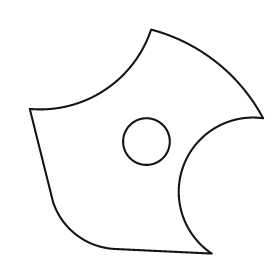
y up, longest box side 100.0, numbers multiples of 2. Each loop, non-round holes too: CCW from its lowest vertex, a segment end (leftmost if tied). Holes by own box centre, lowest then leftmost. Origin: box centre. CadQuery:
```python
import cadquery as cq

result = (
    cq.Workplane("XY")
    .moveTo(28.0, -48.0)
    .threePointArc((16.0, -10.0), (50.0, 10.0))
    .threePointArc((30.0, 34.0), (2.0, 48.0))
    .threePointArc((-18.0, 22.0), (-50.0, 14.0))
    .lineTo(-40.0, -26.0)
    .threePointArc((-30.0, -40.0), (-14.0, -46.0))
    .close()
    .moveTo(0.0, 0.0)
    .circle(10.0)
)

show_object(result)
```